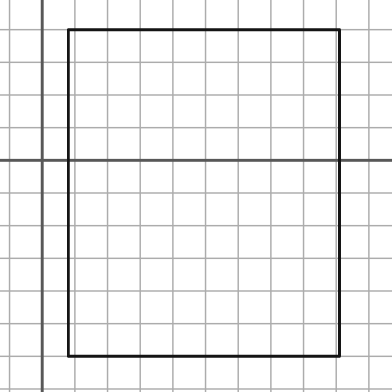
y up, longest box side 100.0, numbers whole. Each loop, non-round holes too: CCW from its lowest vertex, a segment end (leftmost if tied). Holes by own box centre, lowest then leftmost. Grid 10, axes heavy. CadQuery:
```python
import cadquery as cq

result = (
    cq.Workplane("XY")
    .moveTo(8.0, -60.0)
    .lineTo(91.0, -60.0)
    .lineTo(91.0, 40.0)
    .lineTo(8.0, 40.0)
    .close()
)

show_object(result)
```